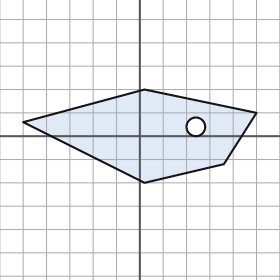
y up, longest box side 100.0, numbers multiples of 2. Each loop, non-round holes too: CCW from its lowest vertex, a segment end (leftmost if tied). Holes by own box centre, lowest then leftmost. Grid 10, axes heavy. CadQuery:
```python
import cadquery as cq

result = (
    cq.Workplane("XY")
    .moveTo(2.0, -20.0)
    .lineTo(36.0, -12.0)
    .lineTo(50.0, 10.0)
    .lineTo(2.0, 20.0)
    .lineTo(-50.0, 6.0)
    .close()
    .moveTo(24.0, 4.0)
    .circle(4.0)
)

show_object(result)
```